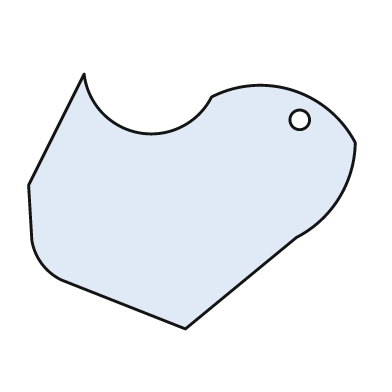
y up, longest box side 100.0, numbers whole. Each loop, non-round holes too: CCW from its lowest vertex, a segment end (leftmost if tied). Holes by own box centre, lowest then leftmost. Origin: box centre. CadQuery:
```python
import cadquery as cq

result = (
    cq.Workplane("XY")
    .moveTo(-2.0, -39.0)
    .lineTo(32.0, -11.0)
    .threePointArc((45.0, 1.0), (50.0, 18.0))
    .threePointArc((31.0, 34.0), (6.0, 32.0))
    .threePointArc((-16.0, 21.0), (-33.0, 39.0))
    .lineTo(-50.0, 5.0)
    .lineTo(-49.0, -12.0)
    .threePointArc((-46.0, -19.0), (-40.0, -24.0))
    .close()
    .moveTo(33.0, 25.0)
    .circle(3.0)
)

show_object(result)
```